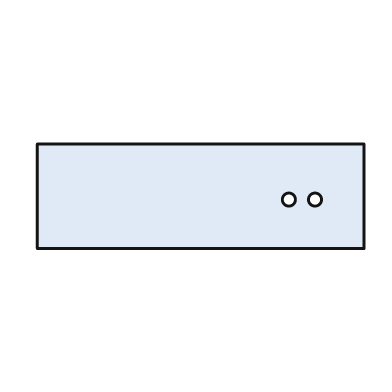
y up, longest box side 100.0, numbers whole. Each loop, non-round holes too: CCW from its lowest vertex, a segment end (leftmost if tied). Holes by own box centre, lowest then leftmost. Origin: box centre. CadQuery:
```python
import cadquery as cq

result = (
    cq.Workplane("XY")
    .moveTo(-50.0, -16.0)
    .lineTo(50.0, -16.0)
    .lineTo(50.0, 16.0)
    .lineTo(-50.0, 16.0)
    .close()
    .moveTo(27.0, -1.0)
    .circle(2.0)
    .moveTo(35.0, -1.0)
    .circle(2.0)
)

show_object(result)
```